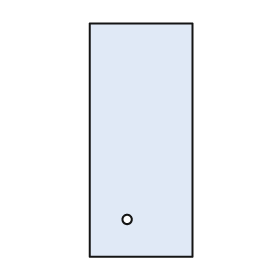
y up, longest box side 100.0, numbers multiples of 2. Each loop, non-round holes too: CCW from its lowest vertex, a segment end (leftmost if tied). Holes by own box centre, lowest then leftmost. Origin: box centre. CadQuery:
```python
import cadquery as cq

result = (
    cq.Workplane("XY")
    .moveTo(-22.0, -50.0)
    .lineTo(22.0, -50.0)
    .lineTo(22.0, 50.0)
    .lineTo(-22.0, 50.0)
    .close()
    .moveTo(-6.0, -34.0)
    .circle(2.0)
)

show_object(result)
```